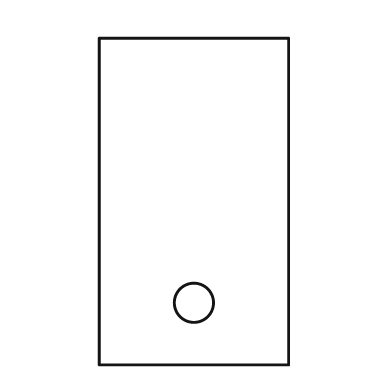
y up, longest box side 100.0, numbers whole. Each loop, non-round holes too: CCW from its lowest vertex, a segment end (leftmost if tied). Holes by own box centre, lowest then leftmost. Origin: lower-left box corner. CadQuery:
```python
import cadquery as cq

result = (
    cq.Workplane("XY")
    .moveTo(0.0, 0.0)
    .lineTo(58.0, 0.0)
    .lineTo(58.0, 100.0)
    .lineTo(0.0, 100.0)
    .close()
    .moveTo(29.0, 19.0)
    .circle(6.0)
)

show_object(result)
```